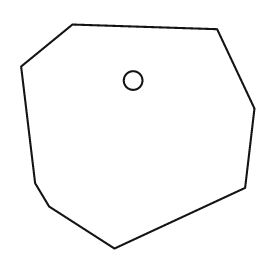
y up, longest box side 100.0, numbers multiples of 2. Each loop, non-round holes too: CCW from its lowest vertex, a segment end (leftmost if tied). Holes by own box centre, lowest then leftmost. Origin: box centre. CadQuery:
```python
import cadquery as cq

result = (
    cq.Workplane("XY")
    .moveTo(-10.0, -48.0)
    .lineTo(46.0, -22.0)
    .lineTo(50.0, 12.0)
    .lineTo(34.0, 46.0)
    .lineTo(-28.0, 48.0)
    .lineTo(-50.0, 30.0)
    .lineTo(-44.0, -20.0)
    .lineTo(-38.0, -30.0)
    .close()
    .moveTo(-2.0, 24.0)
    .circle(4.0)
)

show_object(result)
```